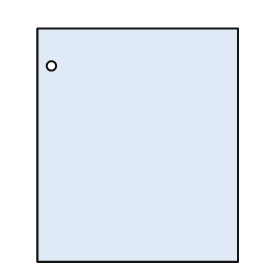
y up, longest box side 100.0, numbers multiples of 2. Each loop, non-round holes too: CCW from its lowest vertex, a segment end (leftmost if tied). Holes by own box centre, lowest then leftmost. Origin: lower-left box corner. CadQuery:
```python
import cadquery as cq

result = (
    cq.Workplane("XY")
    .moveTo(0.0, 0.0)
    .lineTo(86.0, 0.0)
    .lineTo(86.0, 100.0)
    .lineTo(0.0, 100.0)
    .close()
    .moveTo(6.0, 84.0)
    .circle(2.0)
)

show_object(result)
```